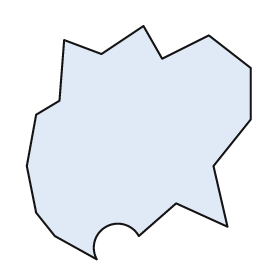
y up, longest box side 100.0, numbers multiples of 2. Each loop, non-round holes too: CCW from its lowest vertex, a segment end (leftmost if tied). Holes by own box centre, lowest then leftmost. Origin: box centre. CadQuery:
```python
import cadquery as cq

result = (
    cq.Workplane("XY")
    .moveTo(-18.0, -50.0)
    .threePointArc((-14.0, -36.0), (0.0, -40.0))
    .lineTo(16.0, -26.0)
    .lineTo(38.0, -36.0)
    .lineTo(32.0, -10.0)
    .lineTo(48.0, 10.0)
    .lineTo(48.0, 32.0)
    .lineTo(30.0, 46.0)
    .lineTo(10.0, 36.0)
    .lineTo(2.0, 50.0)
    .lineTo(-16.0, 38.0)
    .lineTo(-32.0, 44.0)
    .lineTo(-34.0, 18.0)
    .lineTo(-44.0, 12.0)
    .lineTo(-48.0, -10.0)
    .lineTo(-44.0, -30.0)
    .lineTo(-36.0, -40.0)
    .close()
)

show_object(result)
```